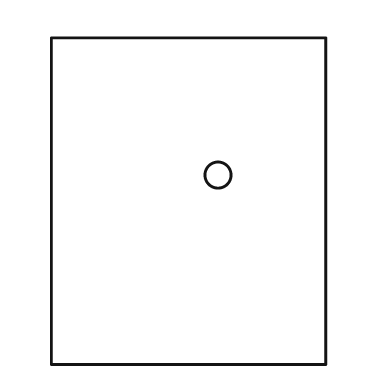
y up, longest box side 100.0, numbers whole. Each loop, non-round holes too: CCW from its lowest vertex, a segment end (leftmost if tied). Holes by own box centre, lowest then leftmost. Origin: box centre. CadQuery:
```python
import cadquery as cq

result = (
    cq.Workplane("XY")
    .moveTo(-42.0, -50.0)
    .lineTo(42.0, -50.0)
    .lineTo(42.0, 50.0)
    .lineTo(-42.0, 50.0)
    .close()
    .moveTo(9.0, 8.0)
    .circle(4.0)
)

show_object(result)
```